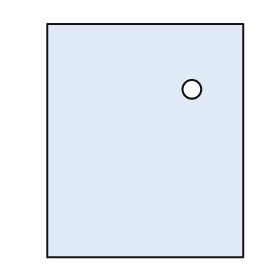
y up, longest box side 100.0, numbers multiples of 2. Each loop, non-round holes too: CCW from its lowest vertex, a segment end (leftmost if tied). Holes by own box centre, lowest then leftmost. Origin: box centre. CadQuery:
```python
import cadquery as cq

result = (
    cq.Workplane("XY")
    .moveTo(-42.0, -50.0)
    .lineTo(42.0, -50.0)
    .lineTo(42.0, 50.0)
    .lineTo(-42.0, 50.0)
    .close()
    .moveTo(20.0, 22.0)
    .circle(4.0)
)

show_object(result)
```